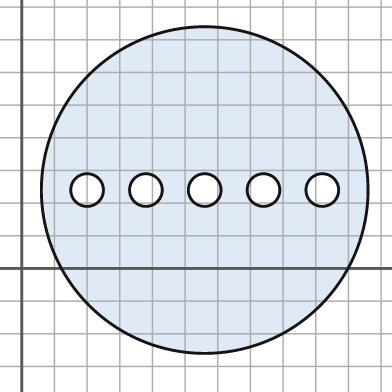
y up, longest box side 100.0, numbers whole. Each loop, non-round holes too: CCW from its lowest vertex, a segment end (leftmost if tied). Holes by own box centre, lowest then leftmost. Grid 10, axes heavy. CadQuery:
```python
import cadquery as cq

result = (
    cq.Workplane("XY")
    .moveTo(56.0, 24.0)
    .circle(50.0)
    .moveTo(20.0, 24.0)
    .circle(5.0)
    .moveTo(38.0, 24.0)
    .circle(5.0)
    .moveTo(56.0, 24.0)
    .circle(5.0)
    .moveTo(74.0, 24.0)
    .circle(5.0)
    .moveTo(92.0, 24.0)
    .circle(5.0)
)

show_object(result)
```